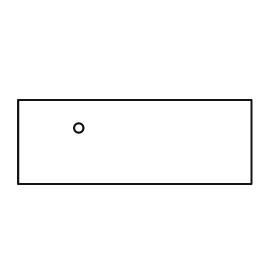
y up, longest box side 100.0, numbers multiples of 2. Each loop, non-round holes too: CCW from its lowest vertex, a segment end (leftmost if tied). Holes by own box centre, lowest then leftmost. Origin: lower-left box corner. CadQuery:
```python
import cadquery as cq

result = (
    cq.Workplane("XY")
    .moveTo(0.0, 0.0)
    .lineTo(100.0, 0.0)
    .lineTo(100.0, 36.0)
    .lineTo(0.0, 36.0)
    .close()
    .moveTo(26.0, 24.0)
    .circle(2.0)
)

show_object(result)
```